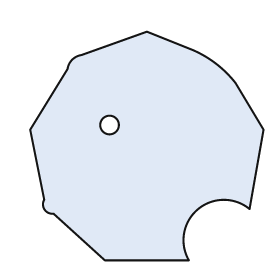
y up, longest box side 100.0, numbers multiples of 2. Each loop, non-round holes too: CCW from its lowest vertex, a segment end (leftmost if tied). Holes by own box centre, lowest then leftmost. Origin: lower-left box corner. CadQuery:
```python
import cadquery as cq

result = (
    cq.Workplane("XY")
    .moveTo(32.0, 0.0)
    .lineTo(68.0, 0.0)
    .threePointArc((72.0, 22.0), (94.0, 22.0))
    .lineTo(100.0, 56.0)
    .lineTo(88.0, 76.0)
    .threePointArc((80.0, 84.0), (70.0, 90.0))
    .lineTo(50.0, 98.0)
    .lineTo(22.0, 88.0)
    .threePointArc((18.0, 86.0), (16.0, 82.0))
    .lineTo(0.0, 56.0)
    .lineTo(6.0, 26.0)
    .threePointArc((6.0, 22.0), (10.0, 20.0))
    .close()
    .moveTo(34.0, 58.0)
    .circle(4.0)
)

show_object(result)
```